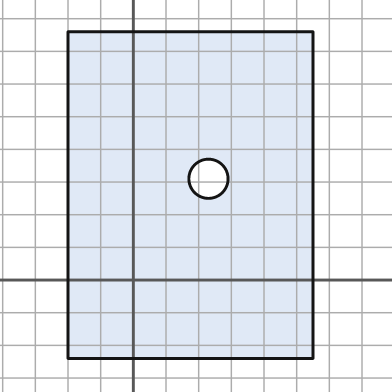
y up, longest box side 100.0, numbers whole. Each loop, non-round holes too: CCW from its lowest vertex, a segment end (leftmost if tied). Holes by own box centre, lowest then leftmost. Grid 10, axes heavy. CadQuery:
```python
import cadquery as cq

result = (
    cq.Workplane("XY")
    .moveTo(-20.0, -24.0)
    .lineTo(55.0, -24.0)
    .lineTo(55.0, 76.0)
    .lineTo(-20.0, 76.0)
    .close()
    .moveTo(23.0, 31.0)
    .circle(6.0)
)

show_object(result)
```